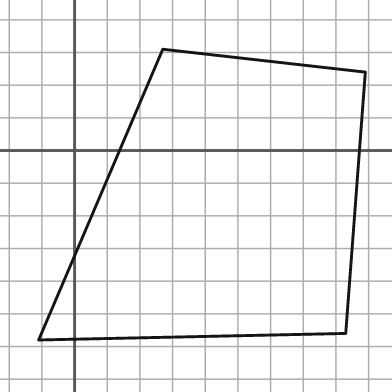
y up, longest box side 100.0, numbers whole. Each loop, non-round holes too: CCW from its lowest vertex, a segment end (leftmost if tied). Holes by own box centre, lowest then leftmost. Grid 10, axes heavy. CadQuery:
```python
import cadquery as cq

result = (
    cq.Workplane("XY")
    .moveTo(-11.0, -58.0)
    .lineTo(83.0, -56.0)
    .lineTo(89.0, 24.0)
    .lineTo(27.0, 31.0)
    .close()
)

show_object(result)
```